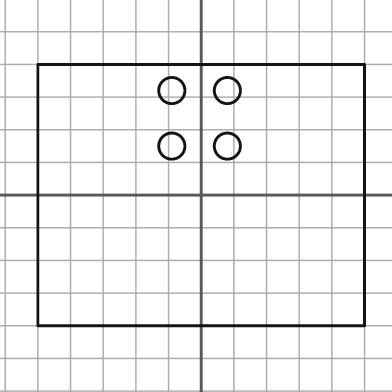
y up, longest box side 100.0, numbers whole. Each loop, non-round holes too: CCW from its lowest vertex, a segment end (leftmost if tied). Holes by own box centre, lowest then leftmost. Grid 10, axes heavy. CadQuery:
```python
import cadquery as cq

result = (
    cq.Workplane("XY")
    .moveTo(-50.0, -40.0)
    .lineTo(50.0, -40.0)
    .lineTo(50.0, 40.0)
    .lineTo(-50.0, 40.0)
    .close()
    .moveTo(-9.0, 15.0)
    .circle(4.0)
    .moveTo(8.0, 15.0)
    .circle(4.0)
    .moveTo(-9.0, 32.0)
    .circle(4.0)
    .moveTo(8.0, 32.0)
    .circle(4.0)
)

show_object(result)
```